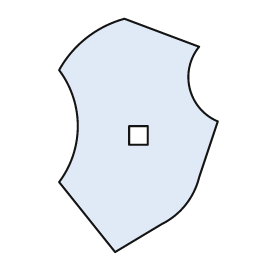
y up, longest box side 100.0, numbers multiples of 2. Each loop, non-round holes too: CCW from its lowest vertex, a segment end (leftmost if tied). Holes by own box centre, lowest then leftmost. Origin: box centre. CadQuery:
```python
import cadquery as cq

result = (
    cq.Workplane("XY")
    .moveTo(-10.0, -50.0)
    .lineTo(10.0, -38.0)
    .threePointArc((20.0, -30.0), (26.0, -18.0))
    .lineTo(34.0, 6.0)
    .threePointArc((22.0, 20.0), (26.0, 38.0))
    .lineTo(-6.0, 50.0)
    .threePointArc((-22.0, 42.0), (-34.0, 28.0))
    .threePointArc((-26.0, 4.0), (-34.0, -20.0))
    .close()
    .moveTo(-4.0, -4.0)
    .lineTo(4.0, -4.0)
    .lineTo(4.0, 4.0)
    .lineTo(-4.0, 4.0)
    .close()
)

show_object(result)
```